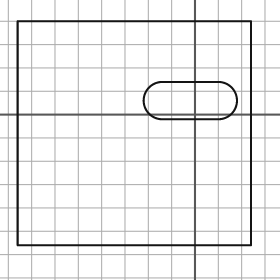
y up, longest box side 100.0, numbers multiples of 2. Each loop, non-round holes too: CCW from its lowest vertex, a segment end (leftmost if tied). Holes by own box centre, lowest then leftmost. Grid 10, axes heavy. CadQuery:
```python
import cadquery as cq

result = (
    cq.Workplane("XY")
    .moveTo(-76.0, -56.0)
    .lineTo(24.0, -56.0)
    .lineTo(24.0, 40.0)
    .lineTo(-76.0, 40.0)
    .close()
    .moveTo(-14.0, -2.0)
    .lineTo(10.0, -2.0)
    .threePointArc((18.0, 6.0), (10.0, 14.0))
    .lineTo(-14.0, 14.0)
    .threePointArc((-22.0, 6.0), (-14.0, -2.0))
    .close()
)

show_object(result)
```